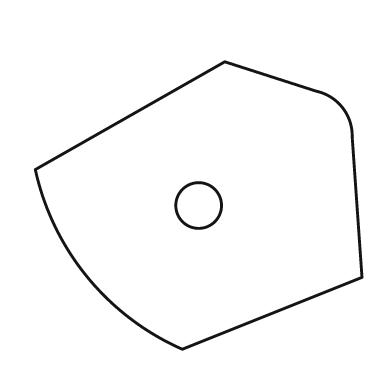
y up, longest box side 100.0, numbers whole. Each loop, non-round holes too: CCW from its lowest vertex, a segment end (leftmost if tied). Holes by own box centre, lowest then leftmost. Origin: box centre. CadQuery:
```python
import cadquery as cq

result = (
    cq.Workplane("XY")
    .moveTo(-5.0, -44.0)
    .lineTo(50.0, -22.0)
    .lineTo(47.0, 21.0)
    .threePointArc((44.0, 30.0), (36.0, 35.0))
    .lineTo(8.0, 44.0)
    .lineTo(-50.0, 11.0)
    .threePointArc((-34.0, -22.0), (-5.0, -44.0))
    .close()
    .moveTo(0.0, 0.0)
    .circle(7.0)
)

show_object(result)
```